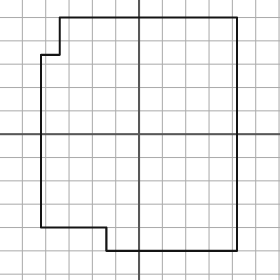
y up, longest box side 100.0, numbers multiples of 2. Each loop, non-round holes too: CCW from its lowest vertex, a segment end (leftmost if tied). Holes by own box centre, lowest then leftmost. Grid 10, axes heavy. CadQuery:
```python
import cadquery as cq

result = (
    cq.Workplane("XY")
    .moveTo(-14.0, -50.0)
    .lineTo(42.0, -50.0)
    .lineTo(42.0, 50.0)
    .lineTo(-34.0, 50.0)
    .lineTo(-34.0, 34.0)
    .lineTo(-42.0, 34.0)
    .lineTo(-42.0, -40.0)
    .lineTo(-14.0, -40.0)
    .close()
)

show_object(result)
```